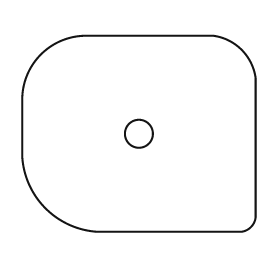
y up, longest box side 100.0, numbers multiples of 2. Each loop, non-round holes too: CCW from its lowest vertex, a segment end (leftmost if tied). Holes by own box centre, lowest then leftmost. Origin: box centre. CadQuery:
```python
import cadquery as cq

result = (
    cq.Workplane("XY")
    .moveTo(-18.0, -42.0)
    .lineTo(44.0, -42.0)
    .threePointArc((48.0, -40.0), (50.0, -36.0))
    .lineTo(50.0, 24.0)
    .threePointArc((44.0, 36.0), (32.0, 42.0))
    .lineTo(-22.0, 42.0)
    .threePointArc((-42.0, 34.0), (-50.0, 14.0))
    .lineTo(-50.0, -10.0)
    .threePointArc((-40.0, -32.0), (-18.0, -42.0))
    .close()
    .moveTo(0.0, 0.0)
    .circle(6.0)
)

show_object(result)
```